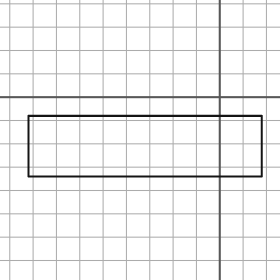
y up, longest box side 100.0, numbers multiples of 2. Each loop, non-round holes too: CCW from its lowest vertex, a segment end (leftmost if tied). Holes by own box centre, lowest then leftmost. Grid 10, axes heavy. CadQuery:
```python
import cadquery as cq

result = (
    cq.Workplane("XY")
    .moveTo(-82.0, -34.0)
    .lineTo(18.0, -34.0)
    .lineTo(18.0, -8.0)
    .lineTo(-82.0, -8.0)
    .close()
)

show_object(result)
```